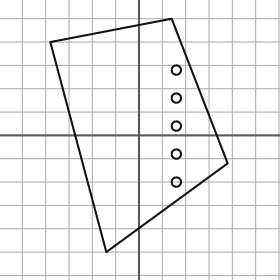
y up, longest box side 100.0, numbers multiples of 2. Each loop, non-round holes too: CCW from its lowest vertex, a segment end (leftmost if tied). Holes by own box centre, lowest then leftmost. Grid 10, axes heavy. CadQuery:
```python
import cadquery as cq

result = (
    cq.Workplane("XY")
    .moveTo(-14.0, -50.0)
    .lineTo(38.0, -12.0)
    .lineTo(14.0, 50.0)
    .lineTo(-38.0, 40.0)
    .close()
    .moveTo(16.0, -20.0)
    .circle(2.0)
    .moveTo(16.0, -8.0)
    .circle(2.0)
    .moveTo(16.0, 4.0)
    .circle(2.0)
    .moveTo(16.0, 16.0)
    .circle(2.0)
    .moveTo(16.0, 28.0)
    .circle(2.0)
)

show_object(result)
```